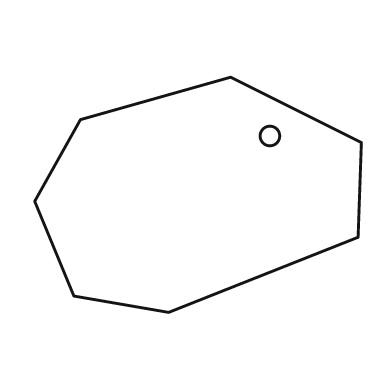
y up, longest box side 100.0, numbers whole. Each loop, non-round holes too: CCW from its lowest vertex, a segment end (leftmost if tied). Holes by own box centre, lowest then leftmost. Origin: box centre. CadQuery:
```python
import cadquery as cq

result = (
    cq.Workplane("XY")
    .moveTo(-9.0, -36.0)
    .lineTo(49.0, -13.0)
    .lineTo(50.0, 16.0)
    .lineTo(10.0, 36.0)
    .lineTo(-36.0, 23.0)
    .lineTo(-50.0, -2.0)
    .lineTo(-38.0, -31.0)
    .close()
    .moveTo(22.0, 18.0)
    .circle(3.0)
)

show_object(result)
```